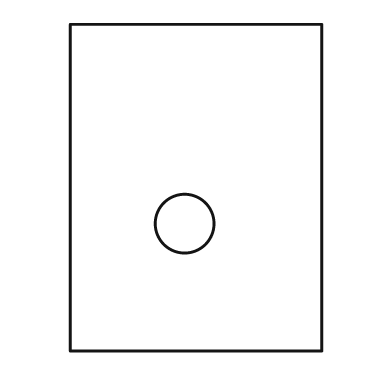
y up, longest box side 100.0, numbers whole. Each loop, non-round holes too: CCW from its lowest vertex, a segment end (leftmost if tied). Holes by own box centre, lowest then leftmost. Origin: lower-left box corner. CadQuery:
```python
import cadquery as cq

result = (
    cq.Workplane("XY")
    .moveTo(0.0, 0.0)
    .lineTo(77.0, 0.0)
    .lineTo(77.0, 100.0)
    .lineTo(0.0, 100.0)
    .close()
    .moveTo(35.0, 39.0)
    .circle(9.0)
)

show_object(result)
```